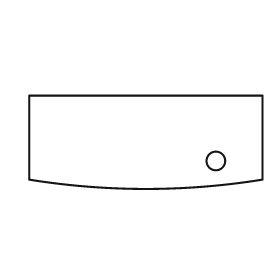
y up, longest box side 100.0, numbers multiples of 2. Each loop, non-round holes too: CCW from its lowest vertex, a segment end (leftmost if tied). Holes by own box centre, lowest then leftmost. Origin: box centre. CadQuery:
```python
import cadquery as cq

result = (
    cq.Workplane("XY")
    .moveTo(-50.0, -16.0)
    .threePointArc((0.0, -20.0), (50.0, -16.0))
    .lineTo(50.0, 20.0)
    .lineTo(-50.0, 20.0)
    .close()
    .moveTo(30.0, -8.0)
    .circle(4.0)
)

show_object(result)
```